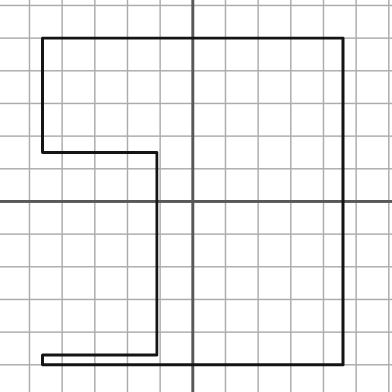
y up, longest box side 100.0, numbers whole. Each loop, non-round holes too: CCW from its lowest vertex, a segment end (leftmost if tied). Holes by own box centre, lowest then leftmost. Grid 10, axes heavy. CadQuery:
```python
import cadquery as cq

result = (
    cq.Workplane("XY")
    .moveTo(-46.0, -50.0)
    .lineTo(46.0, -50.0)
    .lineTo(46.0, 50.0)
    .lineTo(-46.0, 50.0)
    .lineTo(-46.0, 15.0)
    .lineTo(-11.0, 15.0)
    .lineTo(-11.0, -47.0)
    .lineTo(-46.0, -47.0)
    .close()
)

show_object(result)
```